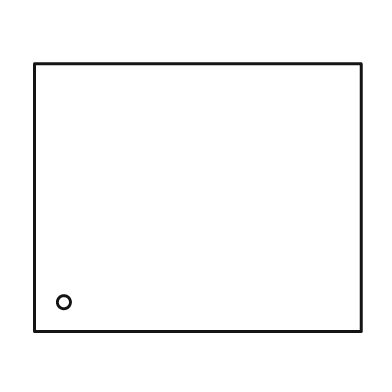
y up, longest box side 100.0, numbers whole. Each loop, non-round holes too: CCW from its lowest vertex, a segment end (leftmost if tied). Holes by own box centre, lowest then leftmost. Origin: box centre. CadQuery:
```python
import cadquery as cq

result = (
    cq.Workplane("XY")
    .moveTo(-50.0, -41.0)
    .lineTo(50.0, -41.0)
    .lineTo(50.0, 41.0)
    .lineTo(-50.0, 41.0)
    .close()
    .moveTo(-41.0, -32.0)
    .circle(2.0)
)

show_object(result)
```